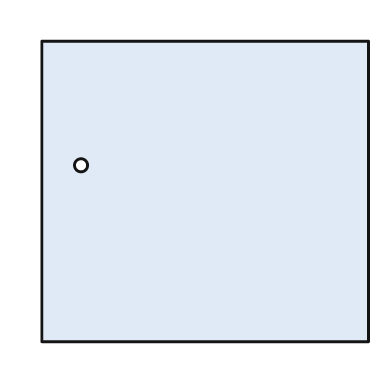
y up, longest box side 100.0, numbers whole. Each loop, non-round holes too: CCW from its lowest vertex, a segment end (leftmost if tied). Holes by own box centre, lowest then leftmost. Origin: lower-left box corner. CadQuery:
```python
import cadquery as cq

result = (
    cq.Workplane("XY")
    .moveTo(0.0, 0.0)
    .lineTo(100.0, 0.0)
    .lineTo(100.0, 92.0)
    .lineTo(0.0, 92.0)
    .close()
    .moveTo(12.0, 54.0)
    .circle(2.0)
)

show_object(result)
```